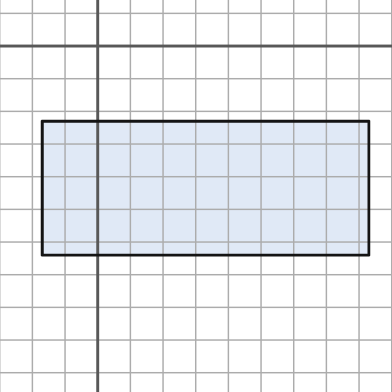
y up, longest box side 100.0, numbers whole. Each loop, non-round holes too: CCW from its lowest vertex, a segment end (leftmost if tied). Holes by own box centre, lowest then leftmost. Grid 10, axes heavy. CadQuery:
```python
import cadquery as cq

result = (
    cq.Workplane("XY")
    .moveTo(-17.0, -64.0)
    .lineTo(83.0, -64.0)
    .lineTo(83.0, -23.0)
    .lineTo(-17.0, -23.0)
    .close()
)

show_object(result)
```